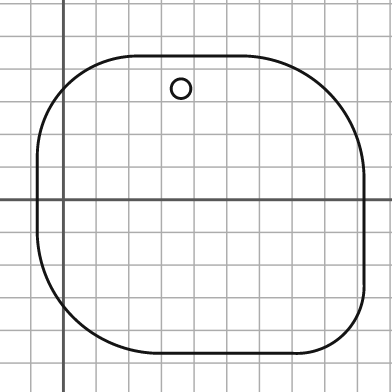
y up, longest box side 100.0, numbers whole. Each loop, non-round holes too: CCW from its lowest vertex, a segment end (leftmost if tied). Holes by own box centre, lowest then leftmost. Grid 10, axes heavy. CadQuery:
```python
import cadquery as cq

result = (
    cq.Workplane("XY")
    .moveTo(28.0, -47.0)
    .lineTo(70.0, -47.0)
    .threePointArc((86.0, -41.0), (92.0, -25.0))
    .lineTo(92.0, 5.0)
    .threePointArc((81.0, 33.0), (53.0, 44.0))
    .lineTo(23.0, 44.0)
    .threePointArc((1.0, 35.0), (-8.0, 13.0))
    .lineTo(-8.0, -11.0)
    .threePointArc((3.0, -36.0), (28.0, -47.0))
    .close()
    .moveTo(36.0, 34.0)
    .circle(3.0)
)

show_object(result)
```